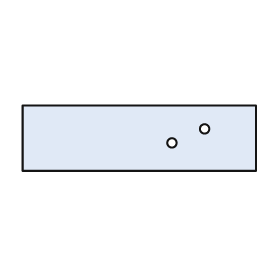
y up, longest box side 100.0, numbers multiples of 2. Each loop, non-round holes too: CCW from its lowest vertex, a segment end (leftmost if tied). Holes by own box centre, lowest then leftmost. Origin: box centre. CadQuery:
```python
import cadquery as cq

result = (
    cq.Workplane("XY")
    .moveTo(-50.0, -14.0)
    .lineTo(50.0, -14.0)
    .lineTo(50.0, 14.0)
    .lineTo(-50.0, 14.0)
    .close()
    .moveTo(14.0, -2.0)
    .circle(2.0)
    .moveTo(28.0, 4.0)
    .circle(2.0)
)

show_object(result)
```